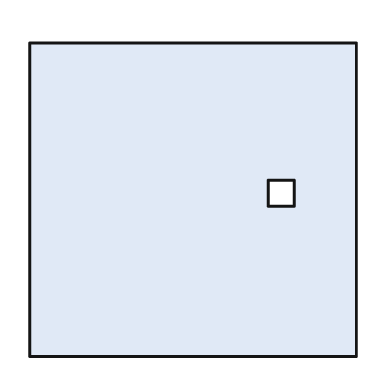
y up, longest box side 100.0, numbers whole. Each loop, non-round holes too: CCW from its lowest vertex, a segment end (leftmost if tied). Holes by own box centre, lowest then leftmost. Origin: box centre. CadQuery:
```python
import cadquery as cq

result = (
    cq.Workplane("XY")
    .moveTo(-50.0, -48.0)
    .lineTo(50.0, -48.0)
    .lineTo(50.0, 48.0)
    .lineTo(-50.0, 48.0)
    .close()
    .moveTo(23.0, -2.0)
    .lineTo(31.0, -2.0)
    .lineTo(31.0, 6.0)
    .lineTo(23.0, 6.0)
    .close()
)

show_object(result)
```